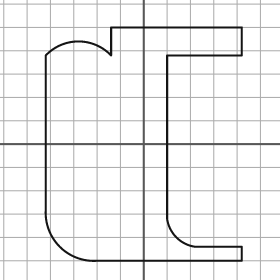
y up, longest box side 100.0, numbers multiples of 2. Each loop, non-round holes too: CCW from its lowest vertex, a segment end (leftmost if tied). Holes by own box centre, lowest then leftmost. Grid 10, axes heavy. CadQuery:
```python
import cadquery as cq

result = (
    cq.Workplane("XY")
    .moveTo(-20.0, -50.0)
    .lineTo(42.0, -50.0)
    .lineTo(42.0, -44.0)
    .lineTo(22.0, -44.0)
    .threePointArc((14.0, -40.0), (10.0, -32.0))
    .lineTo(10.0, 38.0)
    .lineTo(42.0, 38.0)
    .lineTo(42.0, 50.0)
    .lineTo(-14.0, 50.0)
    .lineTo(-14.0, 38.0)
    .threePointArc((-28.0, 44.0), (-42.0, 38.0))
    .lineTo(-42.0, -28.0)
    .threePointArc((-36.0, -44.0), (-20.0, -50.0))
    .close()
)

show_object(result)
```